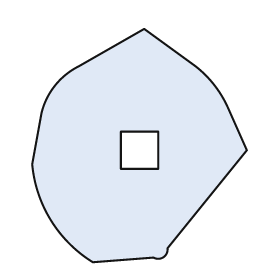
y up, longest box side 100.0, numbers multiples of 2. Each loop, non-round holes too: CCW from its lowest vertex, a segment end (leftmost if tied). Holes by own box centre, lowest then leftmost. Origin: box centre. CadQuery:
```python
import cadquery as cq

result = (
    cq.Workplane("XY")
    .moveTo(-20.0, -50.0)
    .lineTo(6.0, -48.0)
    .threePointArc((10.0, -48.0), (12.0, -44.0))
    .lineTo(46.0, -2.0)
    .lineTo(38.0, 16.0)
    .threePointArc((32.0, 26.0), (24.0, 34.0))
    .lineTo(2.0, 50.0)
    .lineTo(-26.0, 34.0)
    .threePointArc((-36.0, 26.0), (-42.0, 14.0))
    .lineTo(-46.0, -8.0)
    .threePointArc((-38.0, -32.0), (-20.0, -50.0))
    .close()
    .moveTo(-8.0, -10.0)
    .lineTo(8.0, -10.0)
    .lineTo(8.0, 6.0)
    .lineTo(-8.0, 6.0)
    .close()
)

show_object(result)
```